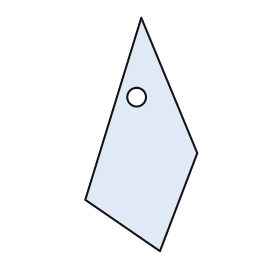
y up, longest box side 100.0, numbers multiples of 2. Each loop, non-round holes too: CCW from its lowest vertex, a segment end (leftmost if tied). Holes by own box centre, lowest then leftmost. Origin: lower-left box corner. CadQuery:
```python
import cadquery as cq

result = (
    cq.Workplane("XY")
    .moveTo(32.0, 0.0)
    .lineTo(48.0, 42.0)
    .lineTo(24.0, 100.0)
    .lineTo(0.0, 22.0)
    .close()
    .moveTo(22.0, 66.0)
    .circle(4.0)
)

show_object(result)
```